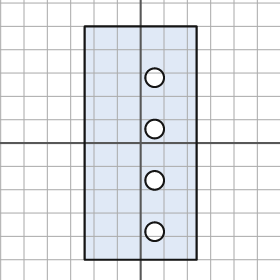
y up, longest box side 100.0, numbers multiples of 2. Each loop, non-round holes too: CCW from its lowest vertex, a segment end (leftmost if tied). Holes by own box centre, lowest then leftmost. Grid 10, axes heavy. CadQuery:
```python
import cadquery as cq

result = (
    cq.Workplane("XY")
    .moveTo(-24.0, -50.0)
    .lineTo(24.0, -50.0)
    .lineTo(24.0, 50.0)
    .lineTo(-24.0, 50.0)
    .close()
    .moveTo(6.0, -38.0)
    .circle(4.0)
    .moveTo(6.0, -16.0)
    .circle(4.0)
    .moveTo(6.0, 6.0)
    .circle(4.0)
    .moveTo(6.0, 28.0)
    .circle(4.0)
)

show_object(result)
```